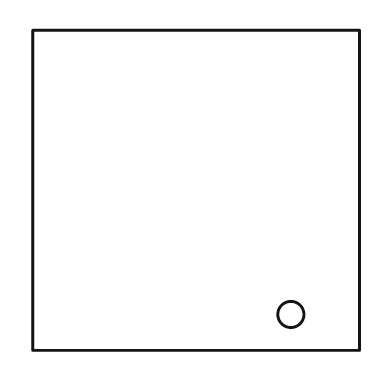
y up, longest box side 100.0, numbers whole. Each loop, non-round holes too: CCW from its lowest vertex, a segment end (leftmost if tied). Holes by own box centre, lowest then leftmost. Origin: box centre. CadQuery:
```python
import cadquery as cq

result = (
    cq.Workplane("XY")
    .moveTo(-50.0, -49.0)
    .lineTo(50.0, -49.0)
    .lineTo(50.0, 49.0)
    .lineTo(-50.0, 49.0)
    .close()
    .moveTo(29.0, -38.0)
    .circle(4.0)
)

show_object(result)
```